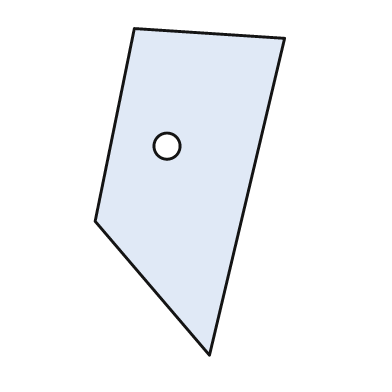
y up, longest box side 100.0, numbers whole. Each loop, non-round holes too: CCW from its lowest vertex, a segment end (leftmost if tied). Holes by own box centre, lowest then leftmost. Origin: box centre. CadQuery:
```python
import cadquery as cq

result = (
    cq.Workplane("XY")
    .moveTo(6.0, -50.0)
    .lineTo(29.0, 47.0)
    .lineTo(-17.0, 50.0)
    .lineTo(-29.0, -9.0)
    .close()
    .moveTo(-7.0, 14.0)
    .circle(4.0)
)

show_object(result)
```